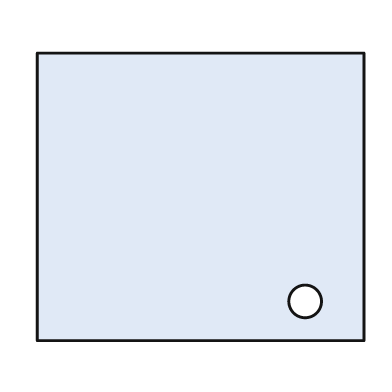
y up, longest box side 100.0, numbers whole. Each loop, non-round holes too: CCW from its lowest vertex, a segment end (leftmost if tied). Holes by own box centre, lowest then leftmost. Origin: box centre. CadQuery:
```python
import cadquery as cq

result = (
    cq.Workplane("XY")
    .moveTo(-50.0, -44.0)
    .lineTo(50.0, -44.0)
    .lineTo(50.0, 44.0)
    .lineTo(-50.0, 44.0)
    .close()
    .moveTo(32.0, -32.0)
    .circle(5.0)
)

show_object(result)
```